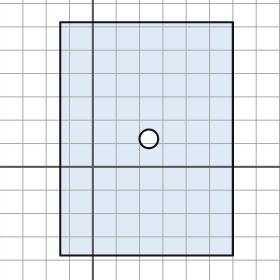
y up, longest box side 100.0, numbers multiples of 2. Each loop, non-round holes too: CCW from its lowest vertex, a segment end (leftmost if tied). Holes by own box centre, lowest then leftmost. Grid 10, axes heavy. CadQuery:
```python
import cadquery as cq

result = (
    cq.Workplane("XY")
    .moveTo(-14.0, -38.0)
    .lineTo(60.0, -38.0)
    .lineTo(60.0, 62.0)
    .lineTo(-14.0, 62.0)
    .close()
    .moveTo(24.0, 12.0)
    .circle(4.0)
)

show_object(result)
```